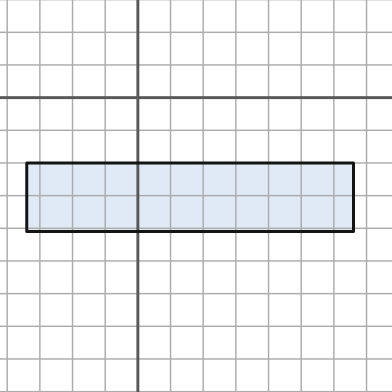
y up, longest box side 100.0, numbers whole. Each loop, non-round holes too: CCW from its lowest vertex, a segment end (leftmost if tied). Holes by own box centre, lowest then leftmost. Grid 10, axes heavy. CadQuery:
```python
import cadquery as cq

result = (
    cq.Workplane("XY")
    .moveTo(-34.0, -41.0)
    .lineTo(66.0, -41.0)
    .lineTo(66.0, -20.0)
    .lineTo(-34.0, -20.0)
    .close()
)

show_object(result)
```